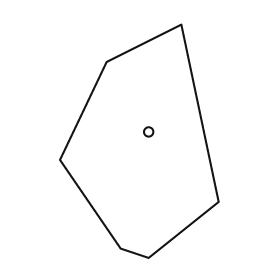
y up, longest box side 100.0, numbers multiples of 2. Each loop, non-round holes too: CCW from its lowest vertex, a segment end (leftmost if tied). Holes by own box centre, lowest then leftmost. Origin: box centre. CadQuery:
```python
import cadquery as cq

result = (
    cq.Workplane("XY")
    .moveTo(4.0, -50.0)
    .lineTo(34.0, -26.0)
    .lineTo(18.0, 50.0)
    .lineTo(-14.0, 34.0)
    .lineTo(-34.0, -8.0)
    .lineTo(-8.0, -46.0)
    .close()
    .moveTo(4.0, 4.0)
    .circle(2.0)
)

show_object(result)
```